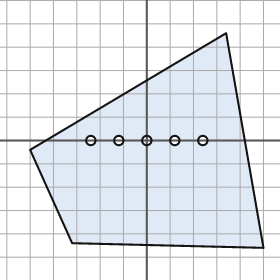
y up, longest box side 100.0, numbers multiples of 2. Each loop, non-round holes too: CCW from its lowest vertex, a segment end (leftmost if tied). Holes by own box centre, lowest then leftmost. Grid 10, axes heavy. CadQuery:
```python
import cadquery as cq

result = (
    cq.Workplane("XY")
    .moveTo(50.0, -46.0)
    .lineTo(34.0, 46.0)
    .lineTo(-50.0, -4.0)
    .lineTo(-32.0, -44.0)
    .close()
    .moveTo(-24.0, 0.0)
    .circle(2.0)
    .moveTo(-12.0, 0.0)
    .circle(2.0)
    .moveTo(0.0, 0.0)
    .circle(2.0)
    .moveTo(12.0, 0.0)
    .circle(2.0)
    .moveTo(24.0, 0.0)
    .circle(2.0)
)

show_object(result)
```